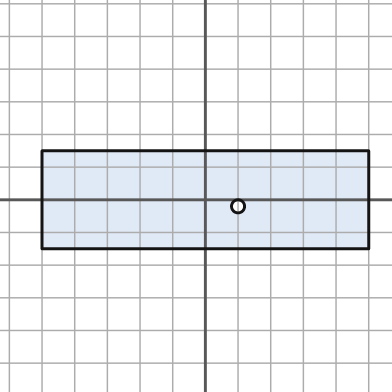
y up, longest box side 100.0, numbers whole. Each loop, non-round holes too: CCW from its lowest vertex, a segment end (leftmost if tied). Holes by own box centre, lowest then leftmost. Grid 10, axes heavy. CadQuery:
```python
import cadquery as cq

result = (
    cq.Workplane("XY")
    .moveTo(-50.0, -15.0)
    .lineTo(50.0, -15.0)
    .lineTo(50.0, 15.0)
    .lineTo(-50.0, 15.0)
    .close()
    .moveTo(10.0, -2.0)
    .circle(2.0)
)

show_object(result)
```